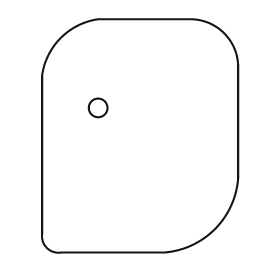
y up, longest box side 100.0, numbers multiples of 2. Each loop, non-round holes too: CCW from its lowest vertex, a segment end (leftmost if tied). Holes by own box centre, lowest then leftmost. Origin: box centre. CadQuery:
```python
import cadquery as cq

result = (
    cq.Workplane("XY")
    .moveTo(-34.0, -50.0)
    .lineTo(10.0, -50.0)
    .threePointArc((32.0, -40.0), (42.0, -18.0))
    .lineTo(42.0, 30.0)
    .threePointArc((36.0, 44.0), (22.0, 50.0))
    .lineTo(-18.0, 50.0)
    .threePointArc((-34.0, 42.0), (-42.0, 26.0))
    .lineTo(-42.0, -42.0)
    .threePointArc((-40.0, -48.0), (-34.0, -50.0))
    .close()
    .moveTo(-18.0, 12.0)
    .circle(4.0)
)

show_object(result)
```